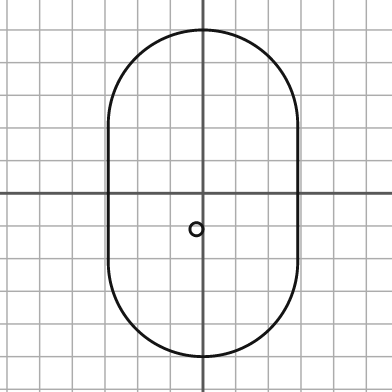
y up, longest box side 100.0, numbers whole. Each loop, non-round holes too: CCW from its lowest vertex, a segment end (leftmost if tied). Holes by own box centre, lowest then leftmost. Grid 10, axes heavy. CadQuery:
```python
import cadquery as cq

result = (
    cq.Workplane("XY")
    .moveTo(-29.0, -21.0)
    .threePointArc((0.0, -50.0), (29.0, -21.0))
    .lineTo(29.0, 21.0)
    .threePointArc((0.0, 50.0), (-29.0, 21.0))
    .close()
    .moveTo(-2.0, -11.0)
    .circle(2.0)
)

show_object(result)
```